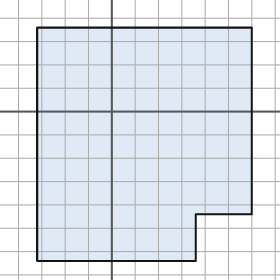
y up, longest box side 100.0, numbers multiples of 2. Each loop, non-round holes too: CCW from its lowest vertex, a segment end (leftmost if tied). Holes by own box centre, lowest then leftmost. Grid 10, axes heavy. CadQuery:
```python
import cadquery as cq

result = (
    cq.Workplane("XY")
    .moveTo(-32.0, -64.0)
    .lineTo(36.0, -64.0)
    .lineTo(36.0, -44.0)
    .lineTo(60.0, -44.0)
    .lineTo(60.0, 36.0)
    .lineTo(-32.0, 36.0)
    .close()
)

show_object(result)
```